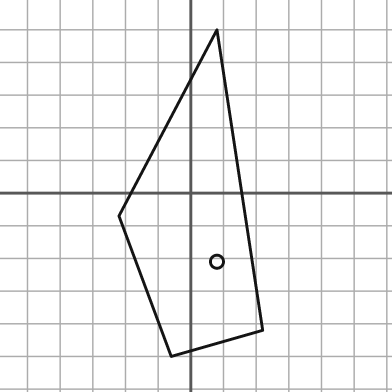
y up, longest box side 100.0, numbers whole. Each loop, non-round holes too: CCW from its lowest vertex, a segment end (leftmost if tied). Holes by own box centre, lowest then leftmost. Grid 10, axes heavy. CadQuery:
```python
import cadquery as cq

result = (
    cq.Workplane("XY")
    .moveTo(-6.0, -50.0)
    .lineTo(22.0, -42.0)
    .lineTo(8.0, 50.0)
    .lineTo(-22.0, -7.0)
    .close()
    .moveTo(8.0, -21.0)
    .circle(2.0)
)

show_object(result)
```